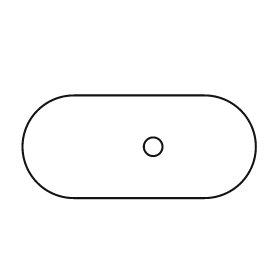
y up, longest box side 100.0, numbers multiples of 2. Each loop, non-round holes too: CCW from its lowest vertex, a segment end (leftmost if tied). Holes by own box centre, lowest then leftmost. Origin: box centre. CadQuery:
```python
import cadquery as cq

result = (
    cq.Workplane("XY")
    .moveTo(-28.0, -22.0)
    .lineTo(28.0, -22.0)
    .threePointArc((50.0, 0.0), (28.0, 22.0))
    .lineTo(-28.0, 22.0)
    .threePointArc((-50.0, 0.0), (-28.0, -22.0))
    .close()
    .moveTo(6.0, 0.0)
    .circle(4.0)
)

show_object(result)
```